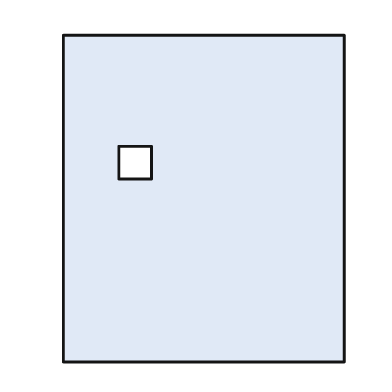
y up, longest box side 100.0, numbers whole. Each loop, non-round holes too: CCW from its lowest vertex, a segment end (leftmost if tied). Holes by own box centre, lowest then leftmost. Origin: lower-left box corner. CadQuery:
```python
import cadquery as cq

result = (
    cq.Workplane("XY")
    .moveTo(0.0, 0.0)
    .lineTo(86.0, 0.0)
    .lineTo(86.0, 100.0)
    .lineTo(0.0, 100.0)
    .close()
    .moveTo(17.0, 56.0)
    .lineTo(27.0, 56.0)
    .lineTo(27.0, 66.0)
    .lineTo(17.0, 66.0)
    .close()
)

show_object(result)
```